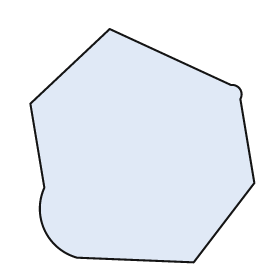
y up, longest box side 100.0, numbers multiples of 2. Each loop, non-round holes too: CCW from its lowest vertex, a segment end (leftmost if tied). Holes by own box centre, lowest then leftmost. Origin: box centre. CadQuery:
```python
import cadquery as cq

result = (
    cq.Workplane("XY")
    .moveTo(22.0, -50.0)
    .lineTo(48.0, -16.0)
    .lineTo(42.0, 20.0)
    .threePointArc((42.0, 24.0), (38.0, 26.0))
    .lineTo(-14.0, 50.0)
    .lineTo(-48.0, 18.0)
    .lineTo(-42.0, -18.0)
    .threePointArc((-42.0, -36.0), (-28.0, -48.0))
    .close()
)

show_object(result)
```